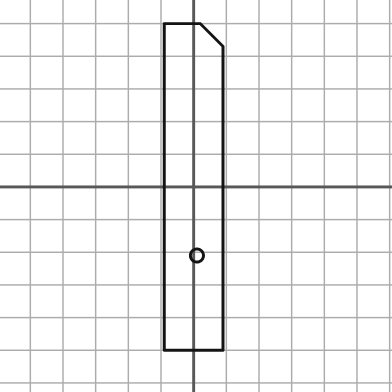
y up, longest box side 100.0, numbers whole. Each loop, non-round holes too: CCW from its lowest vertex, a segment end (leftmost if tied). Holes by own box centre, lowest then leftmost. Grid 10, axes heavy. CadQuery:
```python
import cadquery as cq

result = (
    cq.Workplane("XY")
    .moveTo(-9.0, -50.0)
    .lineTo(9.0, -50.0)
    .lineTo(9.0, 43.0)
    .lineTo(2.0, 50.0)
    .lineTo(-9.0, 50.0)
    .close()
    .moveTo(1.0, -21.0)
    .circle(2.0)
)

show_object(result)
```